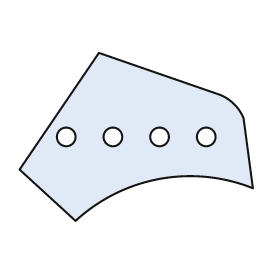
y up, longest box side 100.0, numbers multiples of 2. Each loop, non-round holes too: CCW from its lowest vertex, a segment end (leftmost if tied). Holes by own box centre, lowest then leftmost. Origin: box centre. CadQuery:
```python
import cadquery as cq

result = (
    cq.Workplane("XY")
    .moveTo(-26.0, -36.0)
    .threePointArc((10.0, -18.0), (50.0, -22.0))
    .lineTo(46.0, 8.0)
    .threePointArc((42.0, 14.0), (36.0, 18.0))
    .lineTo(-16.0, 36.0)
    .lineTo(-50.0, -14.0)
    .close()
    .moveTo(-30.0, 0.0)
    .circle(4.0)
    .moveTo(-10.0, 0.0)
    .circle(4.0)
    .moveTo(10.0, 0.0)
    .circle(4.0)
    .moveTo(30.0, 0.0)
    .circle(4.0)
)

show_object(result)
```